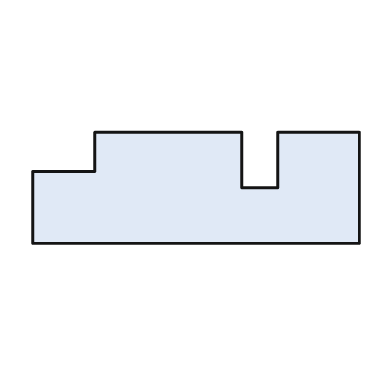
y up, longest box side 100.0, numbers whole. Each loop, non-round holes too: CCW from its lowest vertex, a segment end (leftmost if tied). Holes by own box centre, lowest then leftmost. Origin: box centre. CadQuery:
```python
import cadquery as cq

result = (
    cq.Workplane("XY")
    .moveTo(-50.0, -17.0)
    .lineTo(50.0, -17.0)
    .lineTo(50.0, 17.0)
    .lineTo(25.0, 17.0)
    .lineTo(25.0, 0.0)
    .lineTo(14.0, 0.0)
    .lineTo(14.0, 17.0)
    .lineTo(-31.0, 17.0)
    .lineTo(-31.0, 5.0)
    .lineTo(-50.0, 5.0)
    .close()
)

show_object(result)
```